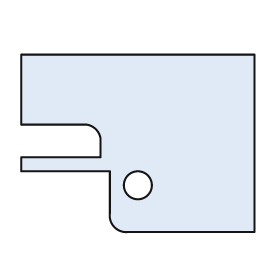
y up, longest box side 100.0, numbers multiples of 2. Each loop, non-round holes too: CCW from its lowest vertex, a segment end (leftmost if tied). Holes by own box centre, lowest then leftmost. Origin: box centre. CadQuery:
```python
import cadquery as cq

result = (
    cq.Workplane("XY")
    .moveTo(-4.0, -38.0)
    .lineTo(50.0, -38.0)
    .lineTo(50.0, 38.0)
    .lineTo(-50.0, 38.0)
    .lineTo(-50.0, 8.0)
    .lineTo(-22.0, 8.0)
    .threePointArc((-18.0, 6.0), (-16.0, 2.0))
    .lineTo(-16.0, -6.0)
    .lineTo(-50.0, -6.0)
    .lineTo(-50.0, -12.0)
    .lineTo(-12.0, -12.0)
    .lineTo(-12.0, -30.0)
    .threePointArc((-10.0, -36.0), (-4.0, -38.0))
    .close()
    .moveTo(0.0, -18.0)
    .circle(6.0)
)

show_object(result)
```